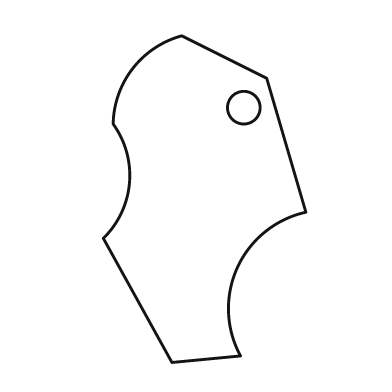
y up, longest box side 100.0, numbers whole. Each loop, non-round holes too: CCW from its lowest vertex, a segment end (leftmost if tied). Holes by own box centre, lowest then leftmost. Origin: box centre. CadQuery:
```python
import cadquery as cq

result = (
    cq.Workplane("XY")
    .moveTo(-10.0, -50.0)
    .lineTo(11.0, -48.0)
    .threePointArc((10.0, -21.0), (31.0, -4.0))
    .lineTo(19.0, 37.0)
    .lineTo(-7.0, 50.0)
    .threePointArc((-22.0, 40.0), (-28.0, 23.0))
    .threePointArc((-23.0, 5.0), (-31.0, -12.0))
    .close()
    .moveTo(12.0, 28.0)
    .circle(5.0)
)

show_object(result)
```